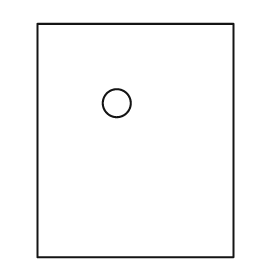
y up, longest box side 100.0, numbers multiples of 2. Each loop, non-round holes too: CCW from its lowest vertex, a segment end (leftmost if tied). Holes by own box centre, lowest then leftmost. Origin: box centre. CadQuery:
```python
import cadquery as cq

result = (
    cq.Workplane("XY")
    .moveTo(-42.0, -50.0)
    .lineTo(42.0, -50.0)
    .lineTo(42.0, 50.0)
    .lineTo(-42.0, 50.0)
    .close()
    .moveTo(-8.0, 16.0)
    .circle(6.0)
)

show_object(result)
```